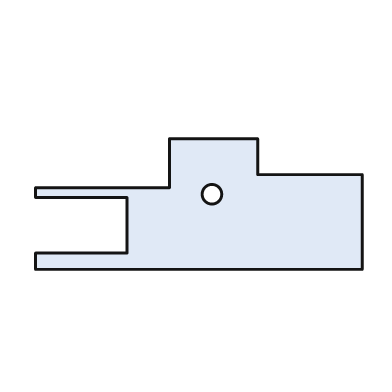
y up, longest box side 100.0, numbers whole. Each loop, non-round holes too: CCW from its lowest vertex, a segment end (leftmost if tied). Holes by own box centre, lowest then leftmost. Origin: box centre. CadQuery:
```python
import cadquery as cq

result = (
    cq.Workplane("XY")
    .moveTo(-50.0, -20.0)
    .lineTo(50.0, -20.0)
    .lineTo(50.0, 9.0)
    .lineTo(18.0, 9.0)
    .lineTo(18.0, 20.0)
    .lineTo(-9.0, 20.0)
    .lineTo(-9.0, 5.0)
    .lineTo(-50.0, 5.0)
    .lineTo(-50.0, 2.0)
    .lineTo(-22.0, 2.0)
    .lineTo(-22.0, -15.0)
    .lineTo(-50.0, -15.0)
    .close()
    .moveTo(4.0, 3.0)
    .circle(3.0)
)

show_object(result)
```